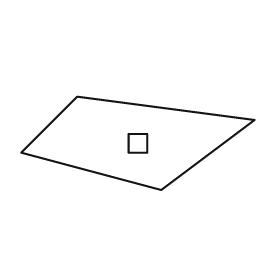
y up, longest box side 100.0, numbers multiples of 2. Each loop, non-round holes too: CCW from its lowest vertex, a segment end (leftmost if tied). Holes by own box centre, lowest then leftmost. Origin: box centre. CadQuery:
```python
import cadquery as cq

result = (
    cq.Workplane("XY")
    .moveTo(10.0, -20.0)
    .lineTo(50.0, 10.0)
    .lineTo(-26.0, 20.0)
    .lineTo(-50.0, -4.0)
    .close()
    .moveTo(-4.0, -4.0)
    .lineTo(4.0, -4.0)
    .lineTo(4.0, 4.0)
    .lineTo(-4.0, 4.0)
    .close()
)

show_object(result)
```